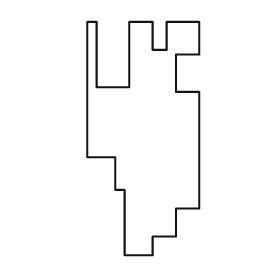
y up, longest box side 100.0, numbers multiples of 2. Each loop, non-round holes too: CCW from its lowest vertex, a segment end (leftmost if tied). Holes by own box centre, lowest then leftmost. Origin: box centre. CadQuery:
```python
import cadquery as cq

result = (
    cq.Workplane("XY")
    .moveTo(-8.0, -50.0)
    .lineTo(4.0, -50.0)
    .lineTo(4.0, -42.0)
    .lineTo(14.0, -42.0)
    .lineTo(14.0, -30.0)
    .lineTo(24.0, -30.0)
    .lineTo(24.0, 20.0)
    .lineTo(14.0, 20.0)
    .lineTo(14.0, 36.0)
    .lineTo(24.0, 36.0)
    .lineTo(24.0, 50.0)
    .lineTo(10.0, 50.0)
    .lineTo(10.0, 38.0)
    .lineTo(4.0, 38.0)
    .lineTo(4.0, 50.0)
    .lineTo(-6.0, 50.0)
    .lineTo(-6.0, 22.0)
    .lineTo(-20.0, 22.0)
    .lineTo(-20.0, 50.0)
    .lineTo(-24.0, 50.0)
    .lineTo(-24.0, -8.0)
    .lineTo(-12.0, -8.0)
    .lineTo(-12.0, -22.0)
    .lineTo(-8.0, -22.0)
    .close()
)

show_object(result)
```